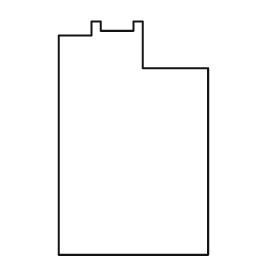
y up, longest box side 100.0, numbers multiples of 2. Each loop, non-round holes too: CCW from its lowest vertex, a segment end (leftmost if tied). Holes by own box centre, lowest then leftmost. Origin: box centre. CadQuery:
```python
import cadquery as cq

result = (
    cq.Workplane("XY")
    .moveTo(-32.0, -50.0)
    .lineTo(32.0, -50.0)
    .lineTo(32.0, 30.0)
    .lineTo(4.0, 30.0)
    .lineTo(4.0, 50.0)
    .lineTo(0.0, 50.0)
    .lineTo(0.0, 46.0)
    .lineTo(-14.0, 46.0)
    .lineTo(-14.0, 50.0)
    .lineTo(-18.0, 50.0)
    .lineTo(-18.0, 44.0)
    .lineTo(-32.0, 44.0)
    .close()
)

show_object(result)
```